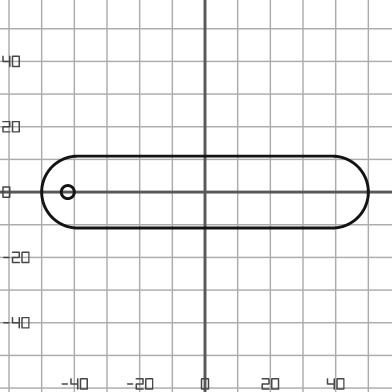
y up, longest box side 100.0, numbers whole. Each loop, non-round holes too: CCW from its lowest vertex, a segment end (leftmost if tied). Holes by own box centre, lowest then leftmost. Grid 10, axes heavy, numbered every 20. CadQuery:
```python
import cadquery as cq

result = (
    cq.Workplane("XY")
    .moveTo(-39.0, -11.0)
    .lineTo(39.0, -11.0)
    .threePointArc((50.0, 0.0), (39.0, 11.0))
    .lineTo(-39.0, 11.0)
    .threePointArc((-50.0, 0.0), (-39.0, -11.0))
    .close()
    .moveTo(-42.0, 0.0)
    .circle(2.0)
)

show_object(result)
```